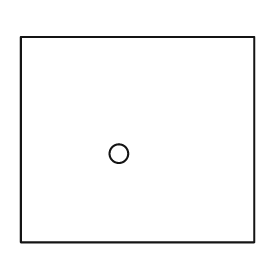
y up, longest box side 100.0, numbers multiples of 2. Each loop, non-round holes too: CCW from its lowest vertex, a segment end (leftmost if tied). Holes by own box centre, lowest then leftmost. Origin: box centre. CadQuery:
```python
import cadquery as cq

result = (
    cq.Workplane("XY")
    .moveTo(-50.0, -44.0)
    .lineTo(50.0, -44.0)
    .lineTo(50.0, 44.0)
    .lineTo(-50.0, 44.0)
    .close()
    .moveTo(-8.0, -6.0)
    .circle(4.0)
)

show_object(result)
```